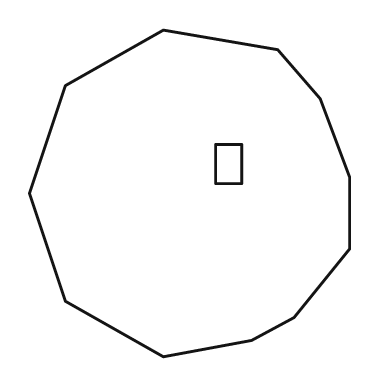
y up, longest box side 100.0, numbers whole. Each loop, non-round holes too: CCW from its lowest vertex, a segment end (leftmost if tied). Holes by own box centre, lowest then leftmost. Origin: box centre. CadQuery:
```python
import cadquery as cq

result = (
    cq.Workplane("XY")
    .moveTo(-8.0, -50.0)
    .lineTo(19.0, -45.0)
    .lineTo(32.0, -38.0)
    .lineTo(49.0, -17.0)
    .lineTo(49.0, 5.0)
    .lineTo(40.0, 29.0)
    .lineTo(27.0, 44.0)
    .lineTo(-8.0, 50.0)
    .lineTo(-38.0, 33.0)
    .lineTo(-49.0, 0.0)
    .lineTo(-38.0, -33.0)
    .close()
    .moveTo(8.0, 3.0)
    .lineTo(16.0, 3.0)
    .lineTo(16.0, 15.0)
    .lineTo(8.0, 15.0)
    .close()
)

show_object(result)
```